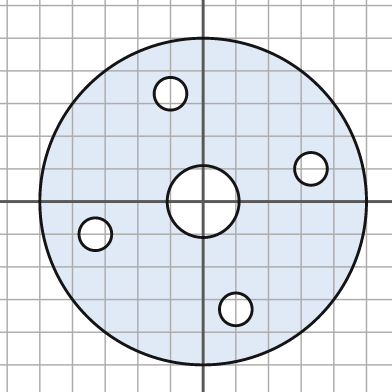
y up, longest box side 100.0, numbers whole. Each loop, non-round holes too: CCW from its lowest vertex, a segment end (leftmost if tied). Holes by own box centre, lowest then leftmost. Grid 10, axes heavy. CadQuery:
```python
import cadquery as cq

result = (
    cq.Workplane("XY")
    .moveTo(0.0, 0.0)
    .circle(50.0)
    .moveTo(10.0, -33.0)
    .circle(5.0)
    .moveTo(-33.0, -10.0)
    .circle(5.0)
    .moveTo(0.0, 0.0)
    .circle(11.0)
    .moveTo(33.0, 10.0)
    .circle(5.0)
    .moveTo(-10.0, 33.0)
    .circle(5.0)
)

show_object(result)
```